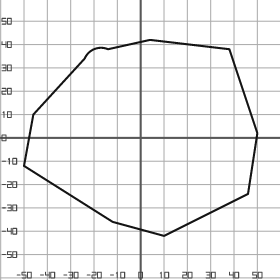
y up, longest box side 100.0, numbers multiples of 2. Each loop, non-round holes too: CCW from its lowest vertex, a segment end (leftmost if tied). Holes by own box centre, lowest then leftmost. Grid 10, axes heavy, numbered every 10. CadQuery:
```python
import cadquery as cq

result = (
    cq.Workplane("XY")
    .moveTo(10.0, -42.0)
    .lineTo(46.0, -24.0)
    .lineTo(50.0, 2.0)
    .lineTo(38.0, 38.0)
    .lineTo(4.0, 42.0)
    .lineTo(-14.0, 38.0)
    .threePointArc((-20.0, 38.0), (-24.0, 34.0))
    .lineTo(-46.0, 10.0)
    .lineTo(-50.0, -12.0)
    .lineTo(-12.0, -36.0)
    .close()
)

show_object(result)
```